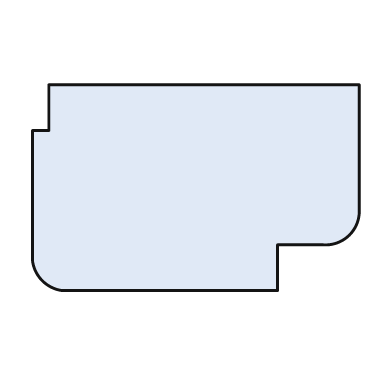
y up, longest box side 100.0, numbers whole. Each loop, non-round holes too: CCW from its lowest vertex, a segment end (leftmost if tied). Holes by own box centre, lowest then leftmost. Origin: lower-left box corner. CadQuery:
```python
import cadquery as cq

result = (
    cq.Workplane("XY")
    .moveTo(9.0, 0.0)
    .lineTo(75.0, 0.0)
    .lineTo(75.0, 14.0)
    .lineTo(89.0, 14.0)
    .threePointArc((97.0, 17.0), (100.0, 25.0))
    .lineTo(100.0, 63.0)
    .lineTo(5.0, 63.0)
    .lineTo(5.0, 49.0)
    .lineTo(0.0, 49.0)
    .lineTo(0.0, 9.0)
    .threePointArc((3.0, 3.0), (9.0, 0.0))
    .close()
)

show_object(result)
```